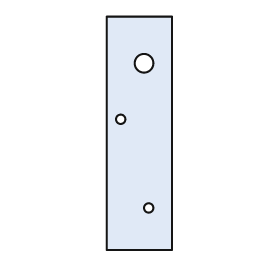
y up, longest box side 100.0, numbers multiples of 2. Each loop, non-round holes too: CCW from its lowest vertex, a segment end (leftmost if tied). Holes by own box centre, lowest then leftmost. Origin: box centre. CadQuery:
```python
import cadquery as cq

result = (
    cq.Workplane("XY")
    .moveTo(-14.0, -50.0)
    .lineTo(14.0, -50.0)
    .lineTo(14.0, 50.0)
    .lineTo(-14.0, 50.0)
    .close()
    .moveTo(4.0, -32.0)
    .circle(2.0)
    .moveTo(-8.0, 6.0)
    .circle(2.0)
    .moveTo(2.0, 30.0)
    .circle(4.0)
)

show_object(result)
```